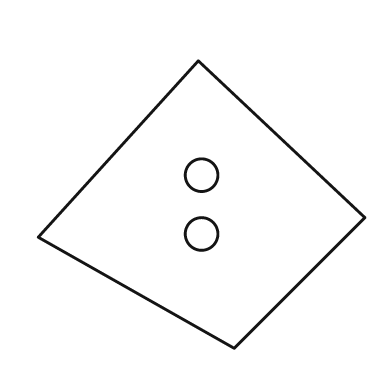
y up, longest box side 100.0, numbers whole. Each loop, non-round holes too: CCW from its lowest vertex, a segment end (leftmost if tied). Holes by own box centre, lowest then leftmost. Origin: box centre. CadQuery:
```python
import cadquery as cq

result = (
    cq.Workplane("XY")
    .moveTo(10.0, -44.0)
    .lineTo(50.0, -4.0)
    .lineTo(-1.0, 44.0)
    .lineTo(-50.0, -10.0)
    .close()
    .moveTo(0.0, -9.0)
    .circle(5.0)
    .moveTo(0.0, 9.0)
    .circle(5.0)
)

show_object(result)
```